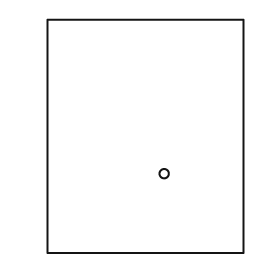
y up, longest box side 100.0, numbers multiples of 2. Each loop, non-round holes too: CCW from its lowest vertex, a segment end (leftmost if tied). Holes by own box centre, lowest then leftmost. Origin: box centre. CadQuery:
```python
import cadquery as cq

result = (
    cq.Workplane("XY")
    .moveTo(-42.0, -50.0)
    .lineTo(42.0, -50.0)
    .lineTo(42.0, 50.0)
    .lineTo(-42.0, 50.0)
    .close()
    .moveTo(8.0, -16.0)
    .circle(2.0)
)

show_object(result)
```